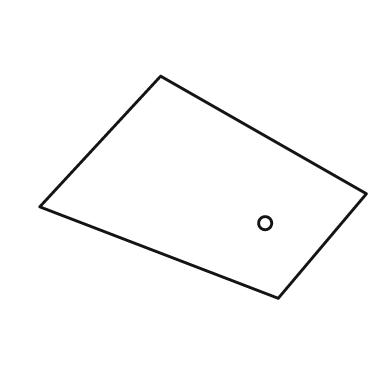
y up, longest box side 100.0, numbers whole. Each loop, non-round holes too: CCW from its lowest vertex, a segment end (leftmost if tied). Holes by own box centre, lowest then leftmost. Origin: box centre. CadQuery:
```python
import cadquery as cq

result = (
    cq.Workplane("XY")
    .moveTo(23.0, -34.0)
    .lineTo(50.0, -2.0)
    .lineTo(-13.0, 34.0)
    .lineTo(-50.0, -6.0)
    .close()
    .moveTo(19.0, -11.0)
    .circle(2.0)
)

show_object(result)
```